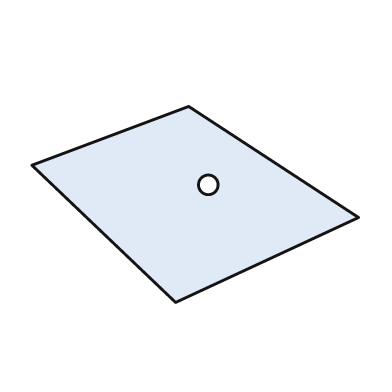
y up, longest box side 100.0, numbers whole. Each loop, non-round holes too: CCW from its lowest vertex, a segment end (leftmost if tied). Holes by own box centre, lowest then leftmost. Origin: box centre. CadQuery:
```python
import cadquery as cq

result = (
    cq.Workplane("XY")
    .moveTo(-6.0, -30.0)
    .lineTo(50.0, -4.0)
    .lineTo(-2.0, 30.0)
    .lineTo(-50.0, 12.0)
    .close()
    .moveTo(4.0, 6.0)
    .circle(3.0)
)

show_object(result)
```